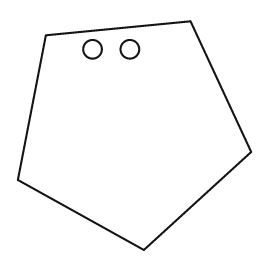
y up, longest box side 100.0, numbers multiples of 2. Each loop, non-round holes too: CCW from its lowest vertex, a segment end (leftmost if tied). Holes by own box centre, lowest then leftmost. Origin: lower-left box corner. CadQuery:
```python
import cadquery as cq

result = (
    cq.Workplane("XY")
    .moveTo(54.0, 0.0)
    .lineTo(100.0, 42.0)
    .lineTo(74.0, 98.0)
    .lineTo(12.0, 92.0)
    .lineTo(0.0, 30.0)
    .close()
    .moveTo(32.0, 86.0)
    .circle(4.0)
    .moveTo(48.0, 86.0)
    .circle(4.0)
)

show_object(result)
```